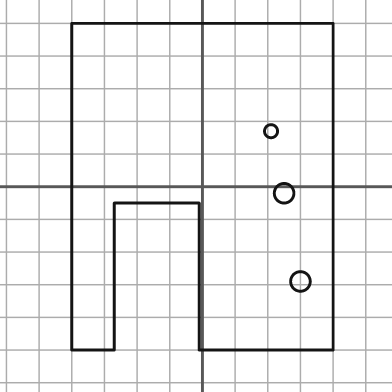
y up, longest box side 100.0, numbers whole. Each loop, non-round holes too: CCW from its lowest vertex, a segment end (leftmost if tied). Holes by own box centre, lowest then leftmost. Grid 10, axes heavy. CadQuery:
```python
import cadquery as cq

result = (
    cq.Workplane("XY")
    .moveTo(-40.0, -50.0)
    .lineTo(-27.0, -50.0)
    .lineTo(-27.0, -5.0)
    .lineTo(-1.0, -5.0)
    .lineTo(-1.0, -50.0)
    .lineTo(40.0, -50.0)
    .lineTo(40.0, 50.0)
    .lineTo(-40.0, 50.0)
    .close()
    .moveTo(30.0, -29.0)
    .circle(3.0)
    .moveTo(25.0, -2.0)
    .circle(3.0)
    .moveTo(21.0, 17.0)
    .circle(2.0)
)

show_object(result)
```